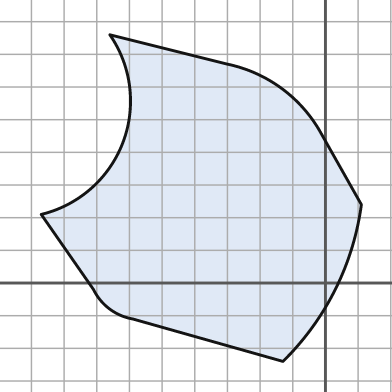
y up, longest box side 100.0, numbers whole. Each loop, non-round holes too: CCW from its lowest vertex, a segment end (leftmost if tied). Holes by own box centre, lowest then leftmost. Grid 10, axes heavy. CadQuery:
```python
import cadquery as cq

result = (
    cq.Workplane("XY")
    .moveTo(-13.0, -24.0)
    .threePointArc((3.0, -2.0), (11.0, 24.0))
    .lineTo(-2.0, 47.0)
    .threePointArc((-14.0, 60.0), (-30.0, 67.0))
    .lineTo(-66.0, 76.0)
    .threePointArc((-62.0, 43.0), (-87.0, 21.0))
    .lineTo(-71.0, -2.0)
    .threePointArc((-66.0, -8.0), (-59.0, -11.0))
    .close()
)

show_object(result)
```